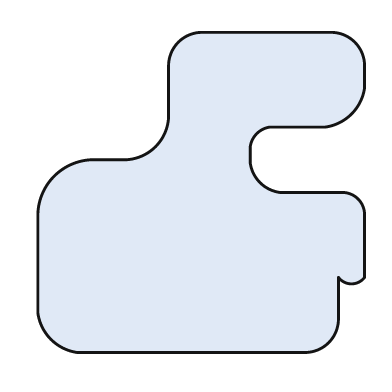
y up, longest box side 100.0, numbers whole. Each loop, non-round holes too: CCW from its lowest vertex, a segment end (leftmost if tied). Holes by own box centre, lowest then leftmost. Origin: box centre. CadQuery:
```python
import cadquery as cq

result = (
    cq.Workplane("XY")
    .moveTo(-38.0, -49.0)
    .lineTo(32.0, -49.0)
    .threePointArc((39.0, -46.0), (42.0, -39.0))
    .lineTo(42.0, -26.0)
    .threePointArc((46.0, -28.0), (50.0, -26.0))
    .lineTo(50.0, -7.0)
    .threePointArc((48.0, -2.0), (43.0, 0.0))
    .lineTo(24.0, 0.0)
    .threePointArc((18.0, 3.0), (15.0, 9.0))
    .lineTo(15.0, 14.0)
    .threePointArc((17.0, 18.0), (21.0, 20.0))
    .lineTo(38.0, 20.0)
    .threePointArc((46.0, 24.0), (50.0, 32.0))
    .lineTo(50.0, 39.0)
    .threePointArc((47.0, 46.0), (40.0, 49.0))
    .lineTo(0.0, 49.0)
    .threePointArc((-7.0, 46.0), (-10.0, 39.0))
    .lineTo(-10.0, 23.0)
    .threePointArc((-14.0, 14.0), (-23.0, 10.0))
    .lineTo(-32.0, 10.0)
    .threePointArc((-45.0, 5.0), (-50.0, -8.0))
    .lineTo(-50.0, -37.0)
    .threePointArc((-46.0, -45.0), (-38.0, -49.0))
    .close()
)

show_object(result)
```